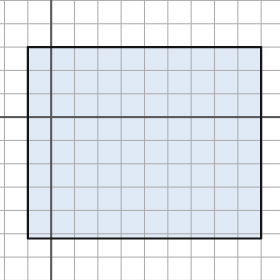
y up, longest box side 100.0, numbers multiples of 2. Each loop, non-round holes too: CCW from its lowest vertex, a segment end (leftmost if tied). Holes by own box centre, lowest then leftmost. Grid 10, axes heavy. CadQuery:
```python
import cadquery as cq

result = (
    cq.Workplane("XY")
    .moveTo(-10.0, -52.0)
    .lineTo(90.0, -52.0)
    .lineTo(90.0, 30.0)
    .lineTo(-10.0, 30.0)
    .close()
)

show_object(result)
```